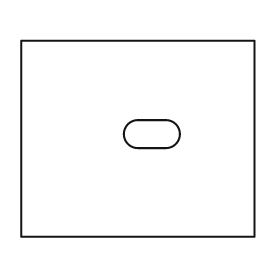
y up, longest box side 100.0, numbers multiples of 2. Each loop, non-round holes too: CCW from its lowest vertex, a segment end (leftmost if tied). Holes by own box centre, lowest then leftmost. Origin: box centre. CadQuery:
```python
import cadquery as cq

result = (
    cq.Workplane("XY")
    .moveTo(-50.0, -42.0)
    .lineTo(50.0, -42.0)
    .lineTo(50.0, 42.0)
    .lineTo(-50.0, 42.0)
    .close()
    .moveTo(0.0, -4.0)
    .lineTo(12.0, -4.0)
    .threePointArc((18.0, 2.0), (12.0, 8.0))
    .lineTo(0.0, 8.0)
    .threePointArc((-6.0, 2.0), (0.0, -4.0))
    .close()
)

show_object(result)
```